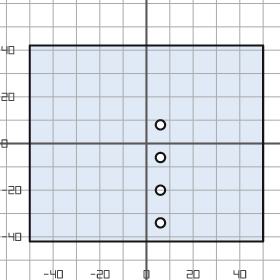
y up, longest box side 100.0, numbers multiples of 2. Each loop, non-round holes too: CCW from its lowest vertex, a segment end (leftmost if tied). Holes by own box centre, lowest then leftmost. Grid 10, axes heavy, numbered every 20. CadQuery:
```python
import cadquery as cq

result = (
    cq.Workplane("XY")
    .moveTo(-50.0, -42.0)
    .lineTo(50.0, -42.0)
    .lineTo(50.0, 42.0)
    .lineTo(-50.0, 42.0)
    .close()
    .moveTo(6.0, -34.0)
    .circle(2.0)
    .moveTo(6.0, -20.0)
    .circle(2.0)
    .moveTo(6.0, -6.0)
    .circle(2.0)
    .moveTo(6.0, 8.0)
    .circle(2.0)
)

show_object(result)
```